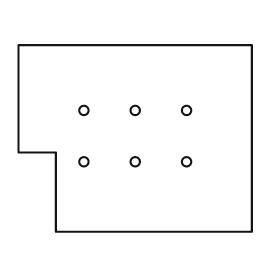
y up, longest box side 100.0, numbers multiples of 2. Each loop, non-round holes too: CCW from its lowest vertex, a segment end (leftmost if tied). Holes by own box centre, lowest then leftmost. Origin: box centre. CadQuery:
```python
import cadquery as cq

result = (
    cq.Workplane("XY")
    .moveTo(-34.0, -40.0)
    .lineTo(50.0, -40.0)
    .lineTo(50.0, 40.0)
    .lineTo(-50.0, 40.0)
    .lineTo(-50.0, -6.0)
    .lineTo(-34.0, -6.0)
    .close()
    .moveTo(-22.0, -10.0)
    .circle(2.0)
    .moveTo(0.0, -10.0)
    .circle(2.0)
    .moveTo(22.0, -10.0)
    .circle(2.0)
    .moveTo(-22.0, 12.0)
    .circle(2.0)
    .moveTo(0.0, 12.0)
    .circle(2.0)
    .moveTo(22.0, 12.0)
    .circle(2.0)
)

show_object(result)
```